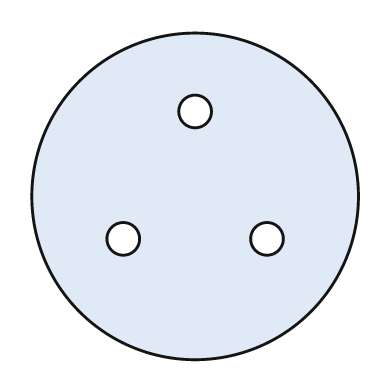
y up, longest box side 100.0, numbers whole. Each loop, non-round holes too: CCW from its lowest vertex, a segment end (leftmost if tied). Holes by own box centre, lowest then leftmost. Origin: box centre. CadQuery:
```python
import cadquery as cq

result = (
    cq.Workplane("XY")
    .moveTo(0.0, 0.0)
    .circle(50.0)
    .moveTo(-22.0, -13.0)
    .circle(5.0)
    .moveTo(22.0, -13.0)
    .circle(5.0)
    .moveTo(0.0, 26.0)
    .circle(5.0)
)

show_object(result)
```